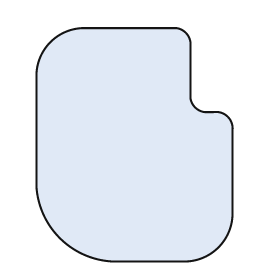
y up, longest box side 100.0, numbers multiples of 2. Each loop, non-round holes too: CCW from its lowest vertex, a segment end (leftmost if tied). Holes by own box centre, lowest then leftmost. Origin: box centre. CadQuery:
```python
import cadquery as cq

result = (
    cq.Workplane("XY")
    .moveTo(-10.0, -50.0)
    .lineTo(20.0, -50.0)
    .threePointArc((36.0, -44.0), (42.0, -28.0))
    .lineTo(42.0, 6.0)
    .threePointArc((40.0, 12.0), (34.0, 14.0))
    .lineTo(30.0, 14.0)
    .threePointArc((26.0, 16.0), (24.0, 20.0))
    .lineTo(24.0, 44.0)
    .threePointArc((22.0, 48.0), (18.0, 50.0))
    .lineTo(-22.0, 50.0)
    .threePointArc((-36.0, 44.0), (-42.0, 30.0))
    .lineTo(-42.0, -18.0)
    .threePointArc((-32.0, -40.0), (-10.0, -50.0))
    .close()
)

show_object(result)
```